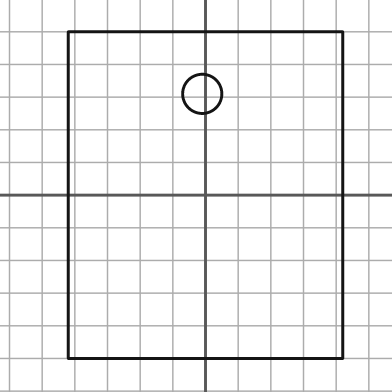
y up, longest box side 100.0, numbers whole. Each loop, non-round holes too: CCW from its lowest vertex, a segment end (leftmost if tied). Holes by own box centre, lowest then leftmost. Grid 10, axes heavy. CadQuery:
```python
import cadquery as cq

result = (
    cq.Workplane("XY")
    .moveTo(-42.0, -50.0)
    .lineTo(42.0, -50.0)
    .lineTo(42.0, 50.0)
    .lineTo(-42.0, 50.0)
    .close()
    .moveTo(-1.0, 31.0)
    .circle(6.0)
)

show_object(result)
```